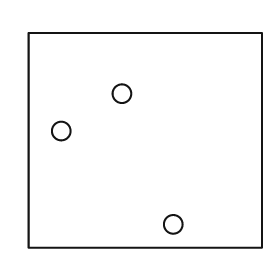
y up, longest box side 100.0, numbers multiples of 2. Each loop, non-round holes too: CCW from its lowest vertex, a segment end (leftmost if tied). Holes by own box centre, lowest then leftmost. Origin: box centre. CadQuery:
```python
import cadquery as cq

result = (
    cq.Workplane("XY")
    .moveTo(-50.0, -46.0)
    .lineTo(50.0, -46.0)
    .lineTo(50.0, 46.0)
    .lineTo(-50.0, 46.0)
    .close()
    .moveTo(12.0, -36.0)
    .circle(4.0)
    .moveTo(-36.0, 4.0)
    .circle(4.0)
    .moveTo(-10.0, 20.0)
    .circle(4.0)
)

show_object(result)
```